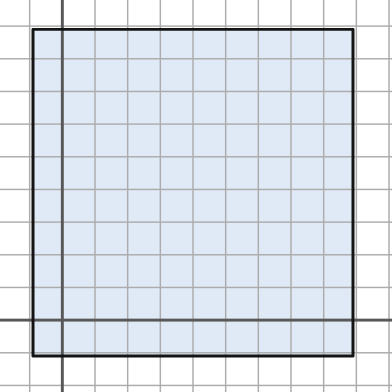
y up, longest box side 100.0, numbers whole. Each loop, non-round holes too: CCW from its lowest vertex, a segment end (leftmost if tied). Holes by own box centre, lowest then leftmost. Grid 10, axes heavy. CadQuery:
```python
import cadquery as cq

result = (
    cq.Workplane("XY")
    .moveTo(-9.0, -11.0)
    .lineTo(89.0, -11.0)
    .lineTo(89.0, 89.0)
    .lineTo(-9.0, 89.0)
    .close()
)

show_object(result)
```